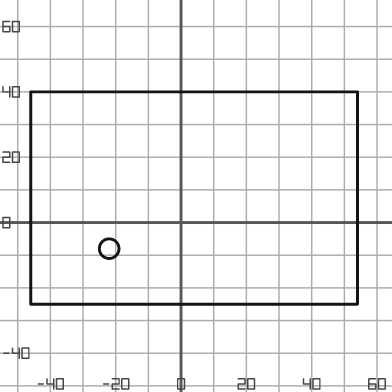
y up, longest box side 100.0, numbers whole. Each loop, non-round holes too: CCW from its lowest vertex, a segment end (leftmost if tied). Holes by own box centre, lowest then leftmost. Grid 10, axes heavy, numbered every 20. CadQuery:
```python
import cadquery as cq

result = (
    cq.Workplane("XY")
    .moveTo(-46.0, -25.0)
    .lineTo(54.0, -25.0)
    .lineTo(54.0, 40.0)
    .lineTo(-46.0, 40.0)
    .close()
    .moveTo(-22.0, -8.0)
    .circle(3.0)
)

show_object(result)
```